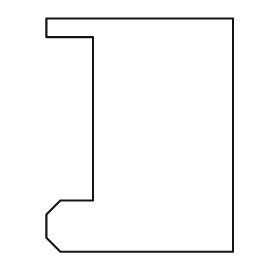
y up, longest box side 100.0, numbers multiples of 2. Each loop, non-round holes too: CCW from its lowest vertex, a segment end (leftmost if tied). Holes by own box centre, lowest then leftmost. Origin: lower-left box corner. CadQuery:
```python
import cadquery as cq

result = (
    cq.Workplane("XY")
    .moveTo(6.0, 0.0)
    .lineTo(80.0, 0.0)
    .lineTo(80.0, 100.0)
    .lineTo(0.0, 100.0)
    .lineTo(0.0, 92.0)
    .lineTo(20.0, 92.0)
    .lineTo(20.0, 22.0)
    .lineTo(6.0, 22.0)
    .lineTo(0.0, 16.0)
    .lineTo(0.0, 6.0)
    .close()
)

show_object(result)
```